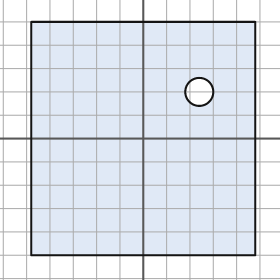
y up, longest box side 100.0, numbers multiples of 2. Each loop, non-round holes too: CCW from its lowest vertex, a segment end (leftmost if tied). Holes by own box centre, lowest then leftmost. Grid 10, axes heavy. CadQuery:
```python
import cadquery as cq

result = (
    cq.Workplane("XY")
    .moveTo(-48.0, -50.0)
    .lineTo(48.0, -50.0)
    .lineTo(48.0, 50.0)
    .lineTo(-48.0, 50.0)
    .close()
    .moveTo(24.0, 20.0)
    .circle(6.0)
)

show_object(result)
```